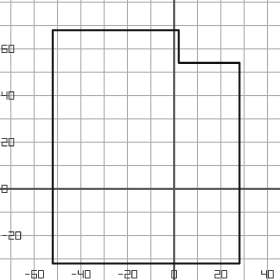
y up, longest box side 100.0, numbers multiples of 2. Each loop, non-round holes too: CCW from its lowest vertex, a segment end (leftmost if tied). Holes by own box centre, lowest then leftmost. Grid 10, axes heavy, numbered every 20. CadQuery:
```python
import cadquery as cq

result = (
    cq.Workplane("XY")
    .moveTo(-52.0, -32.0)
    .lineTo(28.0, -32.0)
    .lineTo(28.0, 54.0)
    .lineTo(2.0, 54.0)
    .lineTo(2.0, 68.0)
    .lineTo(-52.0, 68.0)
    .close()
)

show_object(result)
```